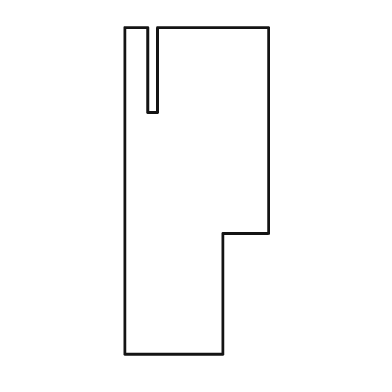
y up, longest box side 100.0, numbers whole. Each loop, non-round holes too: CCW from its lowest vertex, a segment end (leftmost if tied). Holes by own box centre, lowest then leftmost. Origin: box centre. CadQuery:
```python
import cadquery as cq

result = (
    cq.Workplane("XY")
    .moveTo(-22.0, -50.0)
    .lineTo(8.0, -50.0)
    .lineTo(8.0, -13.0)
    .lineTo(22.0, -13.0)
    .lineTo(22.0, 50.0)
    .lineTo(-12.0, 50.0)
    .lineTo(-12.0, 24.0)
    .lineTo(-15.0, 24.0)
    .lineTo(-15.0, 50.0)
    .lineTo(-22.0, 50.0)
    .close()
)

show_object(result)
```